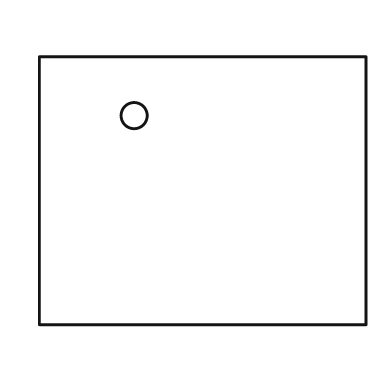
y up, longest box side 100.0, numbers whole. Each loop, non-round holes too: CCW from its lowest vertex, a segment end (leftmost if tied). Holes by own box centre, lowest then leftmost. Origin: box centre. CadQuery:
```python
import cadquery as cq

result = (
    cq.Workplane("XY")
    .moveTo(-50.0, -41.0)
    .lineTo(50.0, -41.0)
    .lineTo(50.0, 41.0)
    .lineTo(-50.0, 41.0)
    .close()
    .moveTo(-21.0, 23.0)
    .circle(4.0)
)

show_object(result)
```